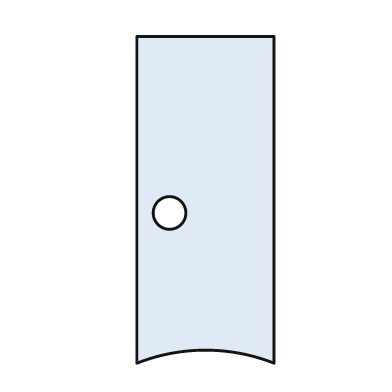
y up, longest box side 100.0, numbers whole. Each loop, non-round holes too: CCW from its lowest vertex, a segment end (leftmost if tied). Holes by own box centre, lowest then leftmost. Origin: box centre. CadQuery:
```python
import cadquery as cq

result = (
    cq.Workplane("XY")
    .moveTo(-21.0, -50.0)
    .threePointArc((0.0, -46.0), (21.0, -50.0))
    .lineTo(21.0, 50.0)
    .lineTo(-21.0, 50.0)
    .close()
    .moveTo(-11.0, -4.0)
    .circle(5.0)
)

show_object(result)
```